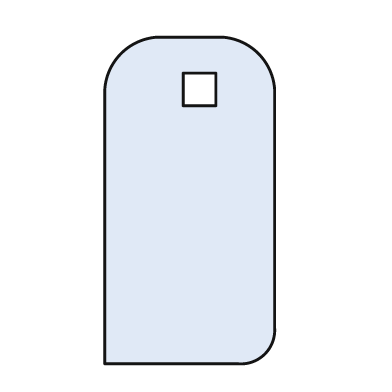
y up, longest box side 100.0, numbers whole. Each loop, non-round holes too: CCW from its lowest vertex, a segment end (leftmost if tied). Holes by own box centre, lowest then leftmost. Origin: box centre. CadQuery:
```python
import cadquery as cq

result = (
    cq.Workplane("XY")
    .moveTo(-26.0, -50.0)
    .lineTo(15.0, -50.0)
    .threePointArc((23.0, -47.0), (26.0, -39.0))
    .lineTo(26.0, 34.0)
    .threePointArc((21.0, 45.0), (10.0, 50.0))
    .lineTo(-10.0, 50.0)
    .threePointArc((-21.0, 45.0), (-26.0, 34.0))
    .close()
    .moveTo(-2.0, 29.0)
    .lineTo(8.0, 29.0)
    .lineTo(8.0, 39.0)
    .lineTo(-2.0, 39.0)
    .close()
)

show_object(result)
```